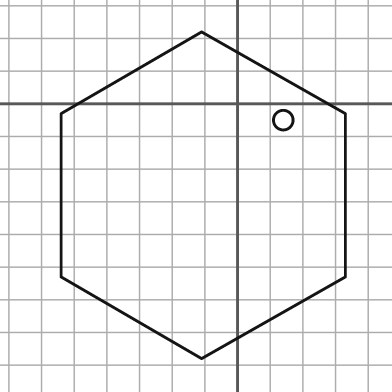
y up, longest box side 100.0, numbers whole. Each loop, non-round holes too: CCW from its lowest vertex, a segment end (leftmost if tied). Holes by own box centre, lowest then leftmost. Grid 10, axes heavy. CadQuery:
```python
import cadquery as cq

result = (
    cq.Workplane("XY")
    .moveTo(-11.0, -78.0)
    .lineTo(33.0, -53.0)
    .lineTo(33.0, -3.0)
    .lineTo(-11.0, 22.0)
    .lineTo(-54.0, -3.0)
    .lineTo(-54.0, -53.0)
    .close()
    .moveTo(14.0, -5.0)
    .circle(3.0)
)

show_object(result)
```